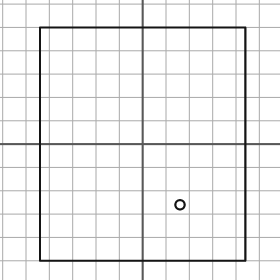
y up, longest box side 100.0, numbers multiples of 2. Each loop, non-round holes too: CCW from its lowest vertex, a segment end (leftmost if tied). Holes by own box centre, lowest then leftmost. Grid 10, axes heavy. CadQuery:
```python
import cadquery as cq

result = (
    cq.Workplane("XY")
    .moveTo(-44.0, -50.0)
    .lineTo(44.0, -50.0)
    .lineTo(44.0, 50.0)
    .lineTo(-44.0, 50.0)
    .close()
    .moveTo(16.0, -26.0)
    .circle(2.0)
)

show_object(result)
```